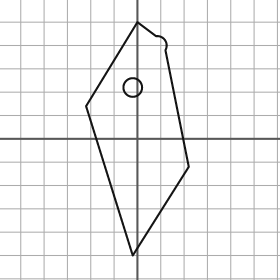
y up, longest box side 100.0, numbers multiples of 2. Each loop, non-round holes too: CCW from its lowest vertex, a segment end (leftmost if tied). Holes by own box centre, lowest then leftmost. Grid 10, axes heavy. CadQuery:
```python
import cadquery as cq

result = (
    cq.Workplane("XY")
    .moveTo(-2.0, -50.0)
    .lineTo(22.0, -12.0)
    .lineTo(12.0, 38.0)
    .threePointArc((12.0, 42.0), (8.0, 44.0))
    .lineTo(0.0, 50.0)
    .lineTo(-22.0, 14.0)
    .close()
    .moveTo(-2.0, 22.0)
    .circle(4.0)
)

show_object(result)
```